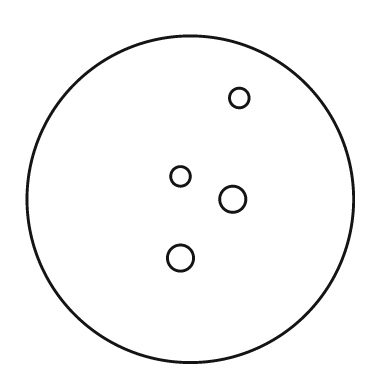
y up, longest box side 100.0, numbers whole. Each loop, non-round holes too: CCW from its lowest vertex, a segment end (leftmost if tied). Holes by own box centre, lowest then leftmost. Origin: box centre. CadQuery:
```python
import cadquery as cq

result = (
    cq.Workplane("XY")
    .moveTo(0.0, 0.0)
    .circle(50.0)
    .moveTo(-3.0, -18.0)
    .circle(4.0)
    .moveTo(13.0, 0.0)
    .circle(4.0)
    .moveTo(-3.0, 7.0)
    .circle(3.0)
    .moveTo(15.0, 31.0)
    .circle(3.0)
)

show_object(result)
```